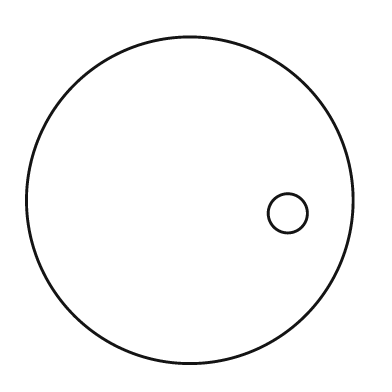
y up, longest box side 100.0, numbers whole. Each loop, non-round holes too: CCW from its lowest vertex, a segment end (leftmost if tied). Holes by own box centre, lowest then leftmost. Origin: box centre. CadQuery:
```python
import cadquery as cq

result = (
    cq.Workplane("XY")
    .moveTo(0.0, 0.0)
    .circle(50.0)
    .moveTo(30.0, -4.0)
    .circle(6.0)
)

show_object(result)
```